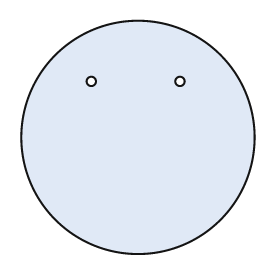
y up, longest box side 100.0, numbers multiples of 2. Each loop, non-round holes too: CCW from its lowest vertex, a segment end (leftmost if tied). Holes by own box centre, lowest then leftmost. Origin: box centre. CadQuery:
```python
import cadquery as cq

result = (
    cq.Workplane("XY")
    .moveTo(0.0, 0.0)
    .circle(50.0)
    .moveTo(-20.0, 24.0)
    .circle(2.0)
    .moveTo(18.0, 24.0)
    .circle(2.0)
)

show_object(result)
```